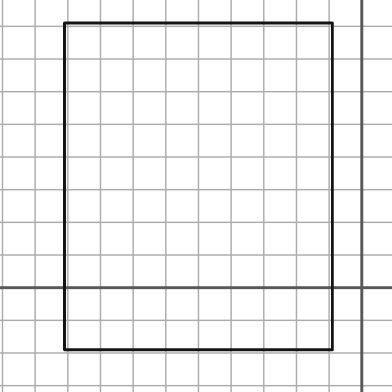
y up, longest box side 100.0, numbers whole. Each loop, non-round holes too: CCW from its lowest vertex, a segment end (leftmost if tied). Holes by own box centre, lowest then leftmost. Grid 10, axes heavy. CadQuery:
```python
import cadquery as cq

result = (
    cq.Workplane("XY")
    .moveTo(-91.0, -19.0)
    .lineTo(-9.0, -19.0)
    .lineTo(-9.0, 81.0)
    .lineTo(-91.0, 81.0)
    .close()
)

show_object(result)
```